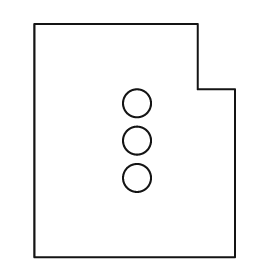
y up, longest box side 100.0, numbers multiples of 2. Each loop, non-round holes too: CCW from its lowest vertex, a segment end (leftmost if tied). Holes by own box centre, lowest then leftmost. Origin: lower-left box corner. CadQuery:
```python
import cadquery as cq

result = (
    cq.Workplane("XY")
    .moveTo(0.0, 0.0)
    .lineTo(86.0, 0.0)
    .lineTo(86.0, 72.0)
    .lineTo(70.0, 72.0)
    .lineTo(70.0, 100.0)
    .lineTo(0.0, 100.0)
    .close()
    .moveTo(44.0, 34.0)
    .circle(6.0)
    .moveTo(44.0, 50.0)
    .circle(6.0)
    .moveTo(44.0, 66.0)
    .circle(6.0)
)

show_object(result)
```